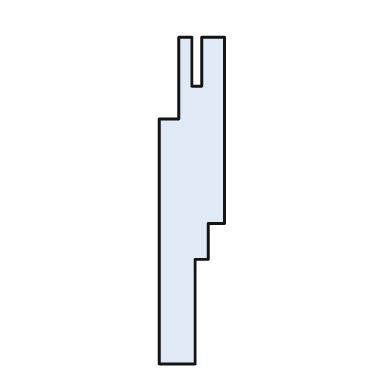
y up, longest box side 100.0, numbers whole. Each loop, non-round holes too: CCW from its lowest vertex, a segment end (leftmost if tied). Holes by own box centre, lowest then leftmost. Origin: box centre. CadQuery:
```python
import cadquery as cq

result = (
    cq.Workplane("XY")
    .moveTo(-10.0, -50.0)
    .lineTo(1.0, -50.0)
    .lineTo(1.0, -18.0)
    .lineTo(5.0, -18.0)
    .lineTo(5.0, -7.0)
    .lineTo(10.0, -7.0)
    .lineTo(10.0, 50.0)
    .lineTo(3.0, 50.0)
    .lineTo(3.0, 35.0)
    .lineTo(0.0, 35.0)
    .lineTo(0.0, 50.0)
    .lineTo(-4.0, 50.0)
    .lineTo(-4.0, 25.0)
    .lineTo(-10.0, 25.0)
    .close()
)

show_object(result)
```